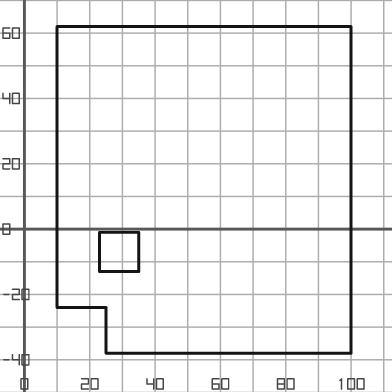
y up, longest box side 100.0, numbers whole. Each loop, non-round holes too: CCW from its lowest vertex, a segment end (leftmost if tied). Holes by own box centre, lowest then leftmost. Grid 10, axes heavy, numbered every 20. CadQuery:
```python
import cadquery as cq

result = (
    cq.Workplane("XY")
    .moveTo(25.0, -38.0)
    .lineTo(100.0, -38.0)
    .lineTo(100.0, 62.0)
    .lineTo(10.0, 62.0)
    .lineTo(10.0, -24.0)
    .lineTo(25.0, -24.0)
    .close()
    .moveTo(23.0, -13.0)
    .lineTo(35.0, -13.0)
    .lineTo(35.0, -1.0)
    .lineTo(23.0, -1.0)
    .close()
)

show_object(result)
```